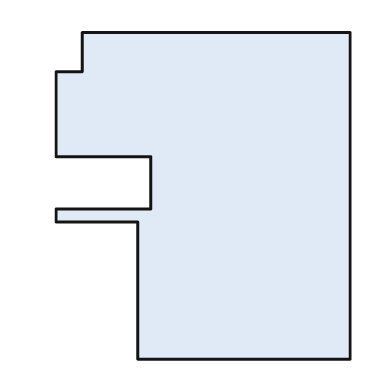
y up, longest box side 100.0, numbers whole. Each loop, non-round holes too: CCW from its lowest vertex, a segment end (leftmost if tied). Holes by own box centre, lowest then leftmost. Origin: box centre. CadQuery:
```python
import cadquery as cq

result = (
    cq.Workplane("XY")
    .moveTo(-20.0, -50.0)
    .lineTo(45.0, -50.0)
    .lineTo(45.0, 50.0)
    .lineTo(-37.0, 50.0)
    .lineTo(-37.0, 38.0)
    .lineTo(-45.0, 38.0)
    .lineTo(-45.0, 12.0)
    .lineTo(-16.0, 12.0)
    .lineTo(-16.0, -4.0)
    .lineTo(-45.0, -4.0)
    .lineTo(-45.0, -8.0)
    .lineTo(-20.0, -8.0)
    .close()
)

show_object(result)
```